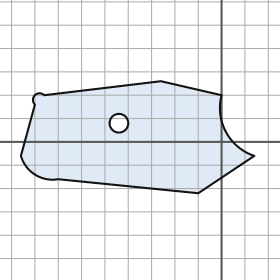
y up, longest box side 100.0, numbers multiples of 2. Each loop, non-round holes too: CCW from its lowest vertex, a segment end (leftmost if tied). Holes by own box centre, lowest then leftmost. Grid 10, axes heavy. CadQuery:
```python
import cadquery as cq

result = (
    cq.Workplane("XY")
    .moveTo(-10.0, -22.0)
    .lineTo(14.0, -6.0)
    .threePointArc((2.0, 4.0), (0.0, 20.0))
    .lineTo(-26.0, 26.0)
    .lineTo(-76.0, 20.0)
    .threePointArc((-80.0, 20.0), (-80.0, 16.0))
    .lineTo(-86.0, -6.0)
    .threePointArc((-80.0, -14.0), (-70.0, -16.0))
    .close()
    .moveTo(-44.0, 8.0)
    .circle(4.0)
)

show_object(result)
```